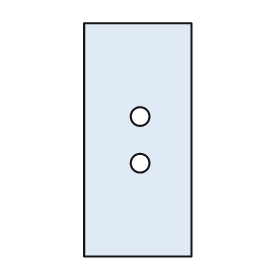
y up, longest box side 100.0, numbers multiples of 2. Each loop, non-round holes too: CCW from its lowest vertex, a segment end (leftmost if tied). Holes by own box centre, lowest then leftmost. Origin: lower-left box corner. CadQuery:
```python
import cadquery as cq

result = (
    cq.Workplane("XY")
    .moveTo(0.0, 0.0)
    .lineTo(46.0, 0.0)
    .lineTo(46.0, 100.0)
    .lineTo(0.0, 100.0)
    .close()
    .moveTo(24.0, 40.0)
    .circle(4.0)
    .moveTo(24.0, 60.0)
    .circle(4.0)
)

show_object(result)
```